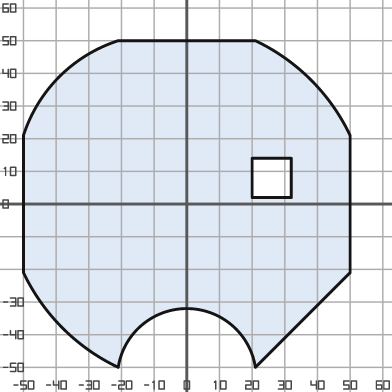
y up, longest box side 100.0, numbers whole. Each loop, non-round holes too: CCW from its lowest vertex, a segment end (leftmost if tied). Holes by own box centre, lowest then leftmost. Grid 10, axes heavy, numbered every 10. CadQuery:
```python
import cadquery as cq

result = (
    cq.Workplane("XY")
    .moveTo(-21.0, -50.0)
    .threePointArc((0.0, -32.0), (21.0, -50.0))
    .lineTo(50.0, -21.0)
    .lineTo(50.0, 21.0)
    .threePointArc((38.0, 38.0), (21.0, 50.0))
    .lineTo(-21.0, 50.0)
    .threePointArc((-39.0, 39.0), (-50.0, 21.0))
    .lineTo(-50.0, -21.0)
    .threePointArc((-38.0, -38.0), (-21.0, -50.0))
    .close()
    .moveTo(20.0, 2.0)
    .lineTo(32.0, 2.0)
    .lineTo(32.0, 14.0)
    .lineTo(20.0, 14.0)
    .close()
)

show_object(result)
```